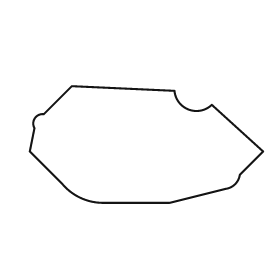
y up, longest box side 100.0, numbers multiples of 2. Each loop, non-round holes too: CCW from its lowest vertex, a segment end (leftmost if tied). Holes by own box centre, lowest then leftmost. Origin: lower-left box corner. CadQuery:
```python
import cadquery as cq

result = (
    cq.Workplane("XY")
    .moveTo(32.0, 0.0)
    .lineTo(60.0, 0.0)
    .lineTo(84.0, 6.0)
    .threePointArc((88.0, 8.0), (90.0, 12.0))
    .lineTo(100.0, 22.0)
    .lineTo(78.0, 42.0)
    .threePointArc((68.0, 40.0), (62.0, 48.0))
    .lineTo(18.0, 50.0)
    .lineTo(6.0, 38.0)
    .threePointArc((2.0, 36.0), (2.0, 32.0))
    .lineTo(0.0, 22.0)
    .lineTo(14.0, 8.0)
    .threePointArc((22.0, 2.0), (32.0, 0.0))
    .close()
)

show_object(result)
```